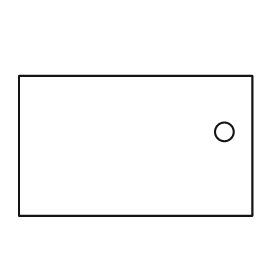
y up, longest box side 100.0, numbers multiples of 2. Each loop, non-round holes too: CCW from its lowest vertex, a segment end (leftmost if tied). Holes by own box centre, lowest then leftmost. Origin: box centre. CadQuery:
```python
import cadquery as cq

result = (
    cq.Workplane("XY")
    .moveTo(-50.0, -30.0)
    .lineTo(50.0, -30.0)
    .lineTo(50.0, 30.0)
    .lineTo(-50.0, 30.0)
    .close()
    .moveTo(38.0, 6.0)
    .circle(4.0)
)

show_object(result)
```